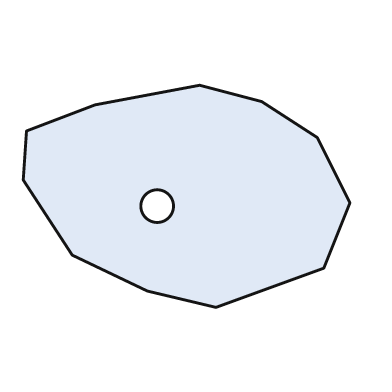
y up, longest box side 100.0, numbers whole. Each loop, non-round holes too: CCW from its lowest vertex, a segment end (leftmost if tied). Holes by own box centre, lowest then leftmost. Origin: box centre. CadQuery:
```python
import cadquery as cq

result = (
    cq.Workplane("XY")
    .moveTo(9.0, -34.0)
    .lineTo(42.0, -22.0)
    .lineTo(50.0, -2.0)
    .lineTo(40.0, 18.0)
    .lineTo(23.0, 29.0)
    .lineTo(4.0, 34.0)
    .lineTo(-28.0, 28.0)
    .lineTo(-49.0, 20.0)
    .lineTo(-50.0, 5.0)
    .lineTo(-35.0, -18.0)
    .lineTo(-12.0, -29.0)
    .close()
    .moveTo(-9.0, -3.0)
    .circle(5.0)
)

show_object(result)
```